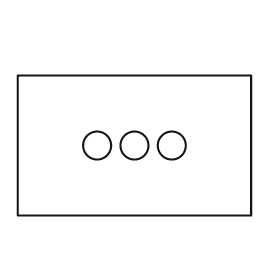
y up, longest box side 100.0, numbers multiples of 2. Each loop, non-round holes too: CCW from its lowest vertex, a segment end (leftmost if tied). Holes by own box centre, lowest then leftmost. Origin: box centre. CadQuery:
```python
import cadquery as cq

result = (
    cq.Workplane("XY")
    .moveTo(-50.0, -30.0)
    .lineTo(50.0, -30.0)
    .lineTo(50.0, 30.0)
    .lineTo(-50.0, 30.0)
    .close()
    .moveTo(-16.0, 0.0)
    .circle(6.0)
    .moveTo(0.0, 0.0)
    .circle(6.0)
    .moveTo(16.0, 0.0)
    .circle(6.0)
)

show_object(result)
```